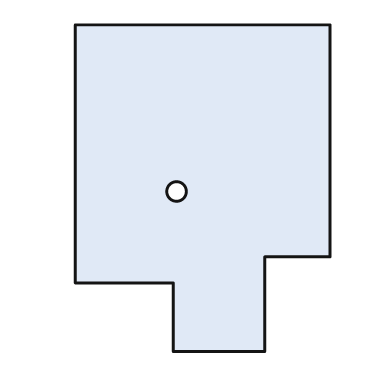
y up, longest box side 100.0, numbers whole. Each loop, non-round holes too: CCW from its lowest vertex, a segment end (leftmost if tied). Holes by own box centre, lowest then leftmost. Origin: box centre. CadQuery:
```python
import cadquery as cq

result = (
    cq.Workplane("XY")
    .moveTo(-9.0, -50.0)
    .lineTo(19.0, -50.0)
    .lineTo(19.0, -21.0)
    .lineTo(39.0, -21.0)
    .lineTo(39.0, 50.0)
    .lineTo(-39.0, 50.0)
    .lineTo(-39.0, -29.0)
    .lineTo(-9.0, -29.0)
    .close()
    .moveTo(-8.0, -1.0)
    .circle(3.0)
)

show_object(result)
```